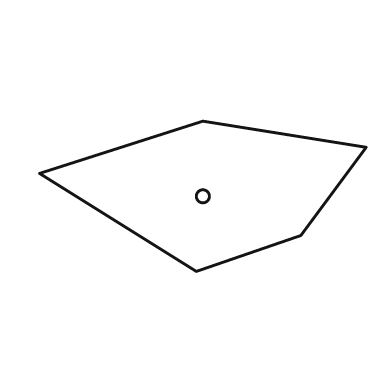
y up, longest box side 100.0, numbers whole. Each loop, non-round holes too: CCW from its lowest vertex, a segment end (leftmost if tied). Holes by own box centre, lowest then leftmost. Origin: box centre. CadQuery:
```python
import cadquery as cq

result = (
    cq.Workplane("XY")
    .moveTo(-2.0, -23.0)
    .lineTo(30.0, -12.0)
    .lineTo(50.0, 15.0)
    .lineTo(0.0, 23.0)
    .lineTo(-50.0, 7.0)
    .close()
    .moveTo(0.0, 0.0)
    .circle(2.0)
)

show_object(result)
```